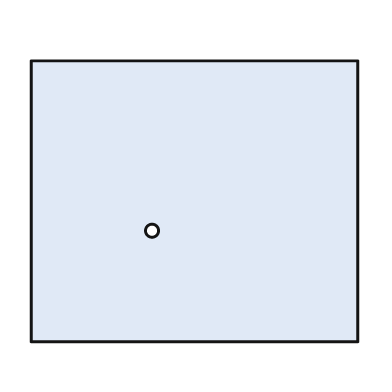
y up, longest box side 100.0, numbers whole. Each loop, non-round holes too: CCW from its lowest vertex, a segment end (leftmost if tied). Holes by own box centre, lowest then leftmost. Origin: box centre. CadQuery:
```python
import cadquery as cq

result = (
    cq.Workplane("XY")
    .moveTo(-50.0, -43.0)
    .lineTo(50.0, -43.0)
    .lineTo(50.0, 43.0)
    .lineTo(-50.0, 43.0)
    .close()
    .moveTo(-13.0, -9.0)
    .circle(2.0)
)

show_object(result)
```